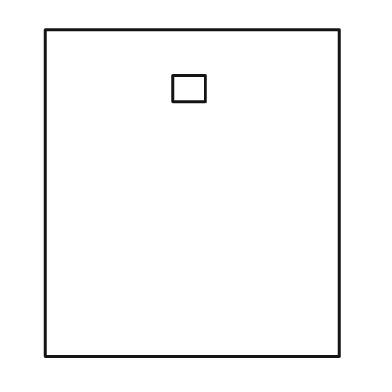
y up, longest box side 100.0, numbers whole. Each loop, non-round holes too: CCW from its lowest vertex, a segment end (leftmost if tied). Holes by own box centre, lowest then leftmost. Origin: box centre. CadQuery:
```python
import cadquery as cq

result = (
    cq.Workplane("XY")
    .moveTo(-45.0, -50.0)
    .lineTo(45.0, -50.0)
    .lineTo(45.0, 50.0)
    .lineTo(-45.0, 50.0)
    .close()
    .moveTo(-6.0, 28.0)
    .lineTo(4.0, 28.0)
    .lineTo(4.0, 36.0)
    .lineTo(-6.0, 36.0)
    .close()
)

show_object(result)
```